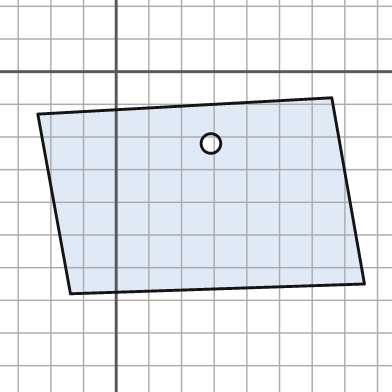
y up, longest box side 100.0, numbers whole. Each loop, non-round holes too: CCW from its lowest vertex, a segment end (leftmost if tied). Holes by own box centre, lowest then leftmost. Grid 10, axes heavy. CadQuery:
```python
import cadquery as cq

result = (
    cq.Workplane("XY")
    .moveTo(-14.0, -68.0)
    .lineTo(76.0, -65.0)
    .lineTo(66.0, -8.0)
    .lineTo(-24.0, -13.0)
    .close()
    .moveTo(29.0, -22.0)
    .circle(3.0)
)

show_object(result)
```